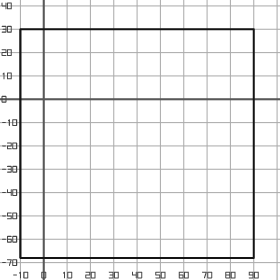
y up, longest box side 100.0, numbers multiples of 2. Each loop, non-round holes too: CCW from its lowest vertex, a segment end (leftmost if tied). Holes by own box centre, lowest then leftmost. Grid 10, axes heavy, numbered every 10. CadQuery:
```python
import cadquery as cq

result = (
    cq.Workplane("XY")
    .moveTo(-10.0, -68.0)
    .lineTo(90.0, -68.0)
    .lineTo(90.0, 30.0)
    .lineTo(-10.0, 30.0)
    .close()
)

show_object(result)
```